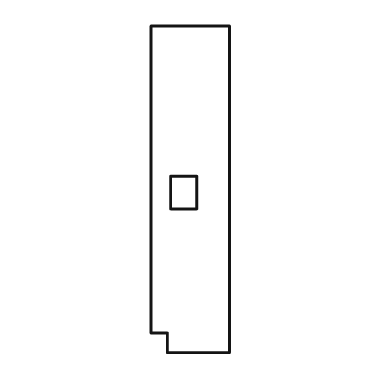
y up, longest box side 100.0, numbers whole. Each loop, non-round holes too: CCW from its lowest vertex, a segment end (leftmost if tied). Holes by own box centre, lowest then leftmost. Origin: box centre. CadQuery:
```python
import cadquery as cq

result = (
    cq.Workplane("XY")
    .moveTo(-7.0, -50.0)
    .lineTo(12.0, -50.0)
    .lineTo(12.0, 50.0)
    .lineTo(-12.0, 50.0)
    .lineTo(-12.0, -44.0)
    .lineTo(-7.0, -44.0)
    .close()
    .moveTo(-6.0, -6.0)
    .lineTo(2.0, -6.0)
    .lineTo(2.0, 4.0)
    .lineTo(-6.0, 4.0)
    .close()
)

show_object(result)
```